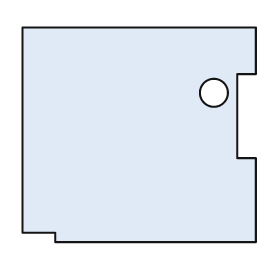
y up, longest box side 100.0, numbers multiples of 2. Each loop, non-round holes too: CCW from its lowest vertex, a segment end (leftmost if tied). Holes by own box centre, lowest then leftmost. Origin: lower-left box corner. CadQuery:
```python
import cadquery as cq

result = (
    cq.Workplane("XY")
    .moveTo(14.0, 0.0)
    .lineTo(100.0, 0.0)
    .lineTo(100.0, 36.0)
    .lineTo(92.0, 36.0)
    .lineTo(92.0, 72.0)
    .lineTo(100.0, 72.0)
    .lineTo(100.0, 92.0)
    .lineTo(0.0, 92.0)
    .lineTo(0.0, 4.0)
    .lineTo(14.0, 4.0)
    .close()
    .moveTo(82.0, 64.0)
    .circle(6.0)
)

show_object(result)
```